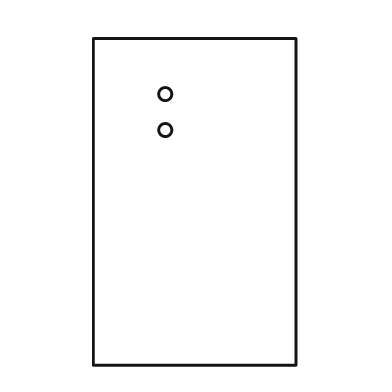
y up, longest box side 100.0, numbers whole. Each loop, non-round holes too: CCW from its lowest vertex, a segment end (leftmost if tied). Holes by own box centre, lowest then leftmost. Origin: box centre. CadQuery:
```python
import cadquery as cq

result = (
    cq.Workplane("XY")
    .moveTo(-31.0, -50.0)
    .lineTo(31.0, -50.0)
    .lineTo(31.0, 50.0)
    .lineTo(-31.0, 50.0)
    .close()
    .moveTo(-9.0, 22.0)
    .circle(2.0)
    .moveTo(-9.0, 33.0)
    .circle(2.0)
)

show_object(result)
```